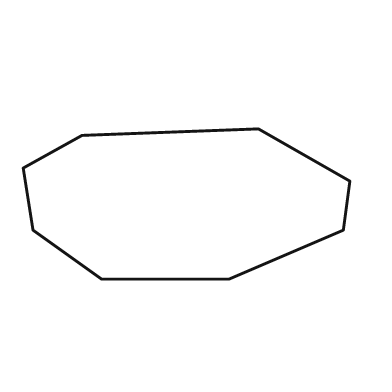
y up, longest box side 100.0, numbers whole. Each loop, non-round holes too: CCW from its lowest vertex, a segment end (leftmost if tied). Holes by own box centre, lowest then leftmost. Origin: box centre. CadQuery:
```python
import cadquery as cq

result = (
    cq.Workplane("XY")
    .moveTo(-26.0, -23.0)
    .lineTo(13.0, -23.0)
    .lineTo(48.0, -8.0)
    .lineTo(50.0, 7.0)
    .lineTo(22.0, 23.0)
    .lineTo(-32.0, 21.0)
    .lineTo(-50.0, 11.0)
    .lineTo(-47.0, -8.0)
    .close()
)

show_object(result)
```